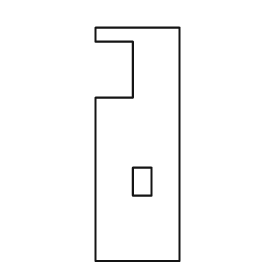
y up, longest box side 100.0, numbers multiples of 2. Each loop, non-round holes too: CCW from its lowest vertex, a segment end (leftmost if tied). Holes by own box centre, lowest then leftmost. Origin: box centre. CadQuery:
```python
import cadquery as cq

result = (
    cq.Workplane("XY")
    .moveTo(-18.0, -50.0)
    .lineTo(18.0, -50.0)
    .lineTo(18.0, 50.0)
    .lineTo(-18.0, 50.0)
    .lineTo(-18.0, 44.0)
    .lineTo(-2.0, 44.0)
    .lineTo(-2.0, 20.0)
    .lineTo(-18.0, 20.0)
    .close()
    .moveTo(-2.0, -22.0)
    .lineTo(6.0, -22.0)
    .lineTo(6.0, -10.0)
    .lineTo(-2.0, -10.0)
    .close()
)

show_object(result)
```